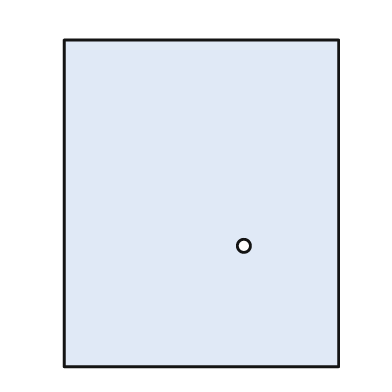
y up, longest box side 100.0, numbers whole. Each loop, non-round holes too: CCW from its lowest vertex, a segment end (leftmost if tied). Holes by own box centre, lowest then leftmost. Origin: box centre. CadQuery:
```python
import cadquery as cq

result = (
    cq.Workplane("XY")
    .moveTo(-42.0, -50.0)
    .lineTo(42.0, -50.0)
    .lineTo(42.0, 50.0)
    .lineTo(-42.0, 50.0)
    .close()
    .moveTo(13.0, -13.0)
    .circle(2.0)
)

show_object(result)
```